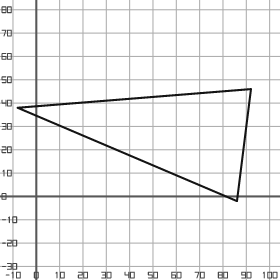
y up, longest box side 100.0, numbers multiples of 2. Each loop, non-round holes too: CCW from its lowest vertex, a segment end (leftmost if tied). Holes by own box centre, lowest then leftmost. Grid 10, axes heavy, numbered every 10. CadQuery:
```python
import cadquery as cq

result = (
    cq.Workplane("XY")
    .moveTo(86.0, -2.0)
    .lineTo(92.0, 46.0)
    .lineTo(-8.0, 38.0)
    .close()
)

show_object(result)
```